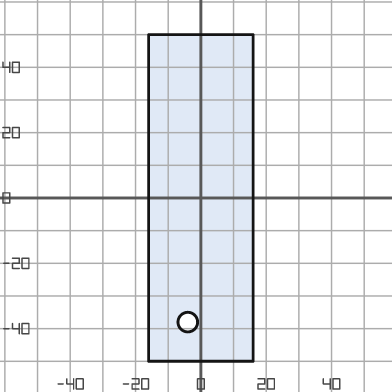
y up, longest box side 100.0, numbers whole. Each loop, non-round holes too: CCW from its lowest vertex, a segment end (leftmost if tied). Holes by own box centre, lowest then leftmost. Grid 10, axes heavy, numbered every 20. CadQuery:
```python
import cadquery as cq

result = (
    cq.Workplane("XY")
    .moveTo(-16.0, -50.0)
    .lineTo(16.0, -50.0)
    .lineTo(16.0, 50.0)
    .lineTo(-16.0, 50.0)
    .close()
    .moveTo(-4.0, -38.0)
    .circle(3.0)
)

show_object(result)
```